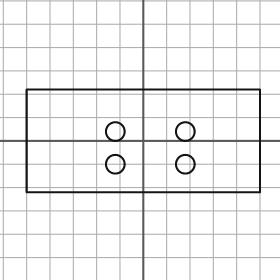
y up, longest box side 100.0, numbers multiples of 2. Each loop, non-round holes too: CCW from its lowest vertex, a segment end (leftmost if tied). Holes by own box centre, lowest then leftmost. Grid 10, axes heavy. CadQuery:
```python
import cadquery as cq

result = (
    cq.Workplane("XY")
    .moveTo(-50.0, -22.0)
    .lineTo(50.0, -22.0)
    .lineTo(50.0, 22.0)
    .lineTo(-50.0, 22.0)
    .close()
    .moveTo(-12.0, -10.0)
    .circle(4.0)
    .moveTo(18.0, -10.0)
    .circle(4.0)
    .moveTo(-12.0, 4.0)
    .circle(4.0)
    .moveTo(18.0, 4.0)
    .circle(4.0)
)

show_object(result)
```